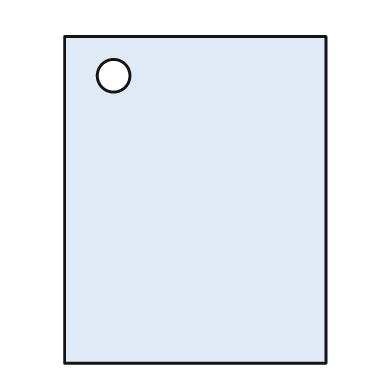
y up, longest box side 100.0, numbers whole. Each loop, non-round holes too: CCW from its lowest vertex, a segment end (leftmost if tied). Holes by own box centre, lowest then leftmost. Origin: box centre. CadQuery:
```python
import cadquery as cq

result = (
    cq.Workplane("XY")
    .moveTo(-40.0, -50.0)
    .lineTo(40.0, -50.0)
    .lineTo(40.0, 50.0)
    .lineTo(-40.0, 50.0)
    .close()
    .moveTo(-25.0, 38.0)
    .circle(5.0)
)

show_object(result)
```